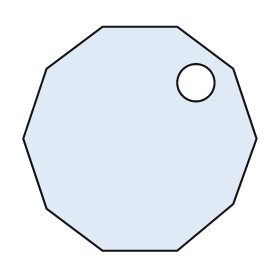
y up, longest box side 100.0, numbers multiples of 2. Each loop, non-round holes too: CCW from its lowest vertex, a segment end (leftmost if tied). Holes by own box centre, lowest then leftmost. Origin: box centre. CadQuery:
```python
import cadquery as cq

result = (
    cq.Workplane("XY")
    .moveTo(-16.0, -48.0)
    .lineTo(16.0, -48.0)
    .lineTo(40.0, -28.0)
    .lineTo(50.0, 0.0)
    .lineTo(40.0, 30.0)
    .lineTo(16.0, 48.0)
    .lineTo(-16.0, 48.0)
    .lineTo(-40.0, 30.0)
    .lineTo(-50.0, 0.0)
    .lineTo(-40.0, -30.0)
    .close()
    .moveTo(24.0, 24.0)
    .circle(8.0)
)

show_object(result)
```